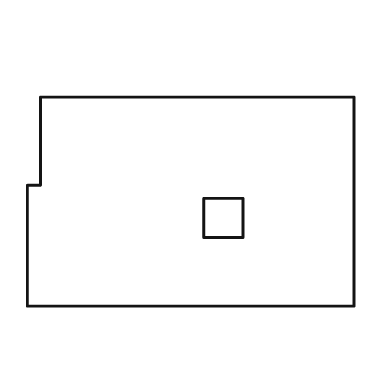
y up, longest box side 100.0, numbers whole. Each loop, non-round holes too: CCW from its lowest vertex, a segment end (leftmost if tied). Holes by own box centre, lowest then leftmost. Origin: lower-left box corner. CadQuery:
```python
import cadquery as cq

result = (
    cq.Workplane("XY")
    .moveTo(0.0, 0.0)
    .lineTo(100.0, 0.0)
    .lineTo(100.0, 64.0)
    .lineTo(4.0, 64.0)
    .lineTo(4.0, 37.0)
    .lineTo(0.0, 37.0)
    .close()
    .moveTo(54.0, 21.0)
    .lineTo(66.0, 21.0)
    .lineTo(66.0, 33.0)
    .lineTo(54.0, 33.0)
    .close()
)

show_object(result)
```